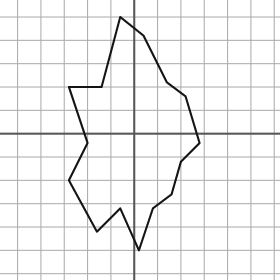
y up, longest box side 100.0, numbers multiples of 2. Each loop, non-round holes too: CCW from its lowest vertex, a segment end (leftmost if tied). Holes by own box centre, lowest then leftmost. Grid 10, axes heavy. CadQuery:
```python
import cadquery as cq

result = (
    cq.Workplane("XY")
    .moveTo(2.0, -50.0)
    .lineTo(8.0, -32.0)
    .lineTo(16.0, -26.0)
    .lineTo(20.0, -12.0)
    .lineTo(28.0, -4.0)
    .lineTo(22.0, 16.0)
    .lineTo(14.0, 22.0)
    .lineTo(4.0, 42.0)
    .lineTo(-6.0, 50.0)
    .lineTo(-14.0, 20.0)
    .lineTo(-28.0, 20.0)
    .lineTo(-20.0, -4.0)
    .lineTo(-28.0, -20.0)
    .lineTo(-16.0, -42.0)
    .lineTo(-6.0, -32.0)
    .close()
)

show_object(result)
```